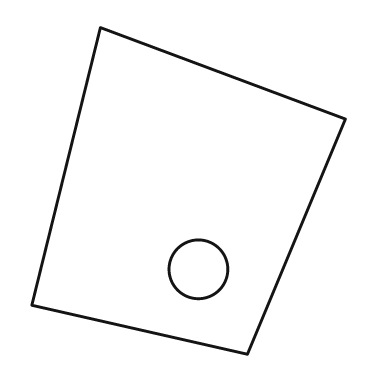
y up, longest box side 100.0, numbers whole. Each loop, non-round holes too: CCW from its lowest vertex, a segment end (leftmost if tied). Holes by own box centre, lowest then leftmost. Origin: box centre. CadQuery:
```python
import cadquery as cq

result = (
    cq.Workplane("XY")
    .moveTo(18.0, -50.0)
    .lineTo(48.0, 22.0)
    .lineTo(-27.0, 50.0)
    .lineTo(-48.0, -35.0)
    .close()
    .moveTo(3.0, -24.0)
    .circle(9.0)
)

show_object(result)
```